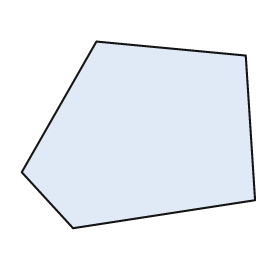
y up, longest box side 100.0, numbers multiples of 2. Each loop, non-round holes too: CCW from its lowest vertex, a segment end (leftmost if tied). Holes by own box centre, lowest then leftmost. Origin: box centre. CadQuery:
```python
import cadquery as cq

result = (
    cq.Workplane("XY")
    .moveTo(-28.0, -40.0)
    .lineTo(50.0, -28.0)
    .lineTo(46.0, 34.0)
    .lineTo(-18.0, 40.0)
    .lineTo(-50.0, -16.0)
    .close()
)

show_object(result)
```